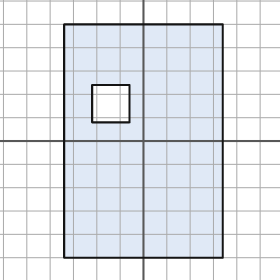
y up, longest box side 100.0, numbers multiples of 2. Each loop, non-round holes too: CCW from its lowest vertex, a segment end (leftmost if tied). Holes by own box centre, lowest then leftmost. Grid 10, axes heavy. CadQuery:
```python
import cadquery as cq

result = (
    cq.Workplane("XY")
    .moveTo(-34.0, -50.0)
    .lineTo(34.0, -50.0)
    .lineTo(34.0, 50.0)
    .lineTo(-34.0, 50.0)
    .close()
    .moveTo(-22.0, 8.0)
    .lineTo(-6.0, 8.0)
    .lineTo(-6.0, 24.0)
    .lineTo(-22.0, 24.0)
    .close()
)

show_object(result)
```